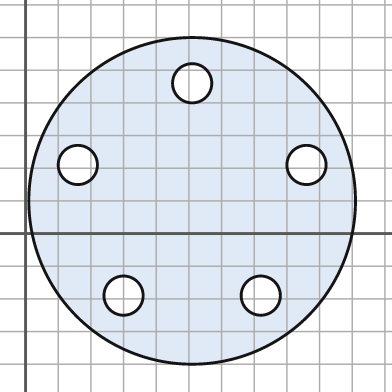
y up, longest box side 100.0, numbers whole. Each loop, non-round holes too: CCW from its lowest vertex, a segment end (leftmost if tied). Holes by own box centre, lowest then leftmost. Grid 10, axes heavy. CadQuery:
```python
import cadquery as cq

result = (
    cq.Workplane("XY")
    .moveTo(51.0, 10.0)
    .circle(50.0)
    .moveTo(30.0, -19.0)
    .circle(6.0)
    .moveTo(72.0, -19.0)
    .circle(6.0)
    .moveTo(16.0, 21.0)
    .circle(6.0)
    .moveTo(86.0, 21.0)
    .circle(6.0)
    .moveTo(51.0, 46.0)
    .circle(6.0)
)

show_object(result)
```